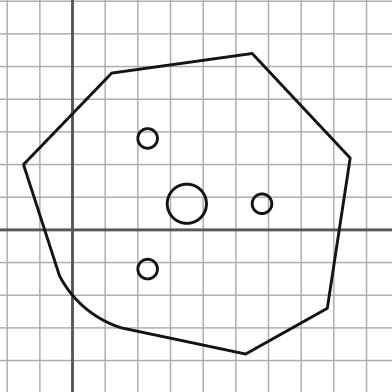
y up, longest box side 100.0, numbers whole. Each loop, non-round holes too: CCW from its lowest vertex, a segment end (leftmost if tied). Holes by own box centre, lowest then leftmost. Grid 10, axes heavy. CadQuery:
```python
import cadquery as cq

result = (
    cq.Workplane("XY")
    .moveTo(53.0, -38.0)
    .lineTo(78.0, -24.0)
    .lineTo(85.0, 22.0)
    .lineTo(55.0, 54.0)
    .lineTo(12.0, 48.0)
    .lineTo(-15.0, 20.0)
    .lineTo(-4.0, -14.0)
    .threePointArc((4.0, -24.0), (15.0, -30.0))
    .close()
    .moveTo(23.0, -12.0)
    .circle(3.0)
    .moveTo(35.0, 8.0)
    .circle(6.0)
    .moveTo(58.0, 8.0)
    .circle(3.0)
    .moveTo(23.0, 28.0)
    .circle(3.0)
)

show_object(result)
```